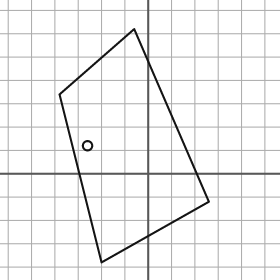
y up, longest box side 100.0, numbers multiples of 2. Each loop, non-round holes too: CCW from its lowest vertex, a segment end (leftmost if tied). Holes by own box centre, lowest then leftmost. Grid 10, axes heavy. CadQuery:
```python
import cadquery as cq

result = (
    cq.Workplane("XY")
    .moveTo(-20.0, -38.0)
    .lineTo(26.0, -12.0)
    .lineTo(-6.0, 62.0)
    .lineTo(-38.0, 34.0)
    .close()
    .moveTo(-26.0, 12.0)
    .circle(2.0)
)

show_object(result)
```